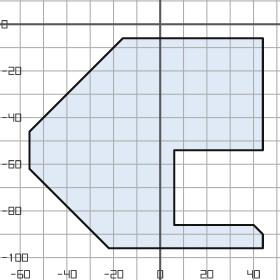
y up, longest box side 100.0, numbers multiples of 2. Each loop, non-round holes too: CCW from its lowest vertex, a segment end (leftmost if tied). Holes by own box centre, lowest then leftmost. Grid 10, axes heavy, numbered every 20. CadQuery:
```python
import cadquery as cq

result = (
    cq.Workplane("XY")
    .moveTo(-22.0, -96.0)
    .lineTo(44.0, -96.0)
    .lineTo(44.0, -90.0)
    .lineTo(40.0, -86.0)
    .lineTo(6.0, -86.0)
    .lineTo(6.0, -54.0)
    .lineTo(44.0, -54.0)
    .lineTo(44.0, -6.0)
    .lineTo(-16.0, -6.0)
    .lineTo(-56.0, -46.0)
    .lineTo(-56.0, -62.0)
    .close()
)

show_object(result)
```